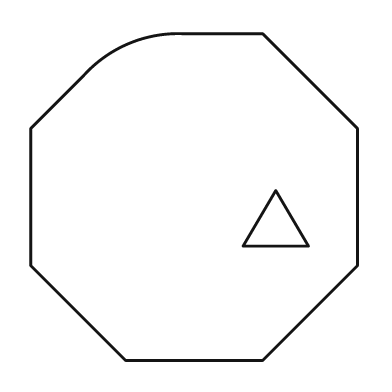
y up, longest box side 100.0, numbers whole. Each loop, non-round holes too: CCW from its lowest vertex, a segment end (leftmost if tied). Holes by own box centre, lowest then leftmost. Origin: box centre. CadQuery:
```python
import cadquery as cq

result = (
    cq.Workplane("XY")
    .moveTo(-21.0, -50.0)
    .lineTo(21.0, -50.0)
    .lineTo(50.0, -21.0)
    .lineTo(50.0, 21.0)
    .lineTo(21.0, 50.0)
    .lineTo(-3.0, 50.0)
    .threePointArc((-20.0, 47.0), (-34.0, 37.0))
    .lineTo(-50.0, 21.0)
    .lineTo(-50.0, -21.0)
    .close()
    .moveTo(15.0, -15.0)
    .lineTo(35.0, -15.0)
    .lineTo(25.0, 2.0)
    .close()
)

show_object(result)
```